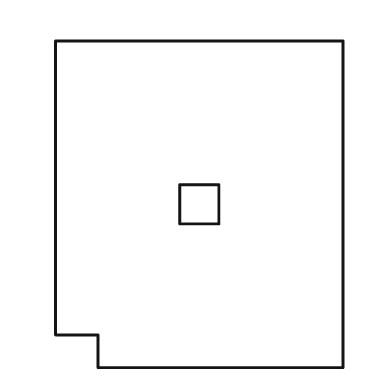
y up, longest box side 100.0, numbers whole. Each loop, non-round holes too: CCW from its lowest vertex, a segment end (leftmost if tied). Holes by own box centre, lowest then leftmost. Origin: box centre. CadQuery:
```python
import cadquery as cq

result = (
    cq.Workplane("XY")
    .moveTo(-31.0, -50.0)
    .lineTo(44.0, -50.0)
    .lineTo(44.0, 50.0)
    .lineTo(-44.0, 50.0)
    .lineTo(-44.0, -40.0)
    .lineTo(-31.0, -40.0)
    .close()
    .moveTo(-6.0, -6.0)
    .lineTo(6.0, -6.0)
    .lineTo(6.0, 6.0)
    .lineTo(-6.0, 6.0)
    .close()
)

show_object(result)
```